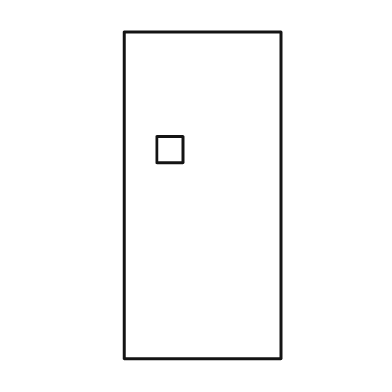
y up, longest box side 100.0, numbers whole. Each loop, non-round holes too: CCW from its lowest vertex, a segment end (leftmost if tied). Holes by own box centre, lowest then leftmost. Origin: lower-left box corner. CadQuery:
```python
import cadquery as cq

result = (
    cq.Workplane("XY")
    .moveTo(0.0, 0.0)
    .lineTo(48.0, 0.0)
    .lineTo(48.0, 100.0)
    .lineTo(0.0, 100.0)
    .close()
    .moveTo(10.0, 60.0)
    .lineTo(18.0, 60.0)
    .lineTo(18.0, 68.0)
    .lineTo(10.0, 68.0)
    .close()
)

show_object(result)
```